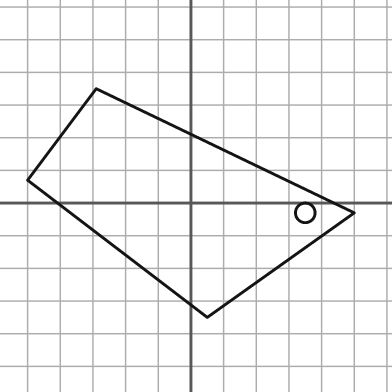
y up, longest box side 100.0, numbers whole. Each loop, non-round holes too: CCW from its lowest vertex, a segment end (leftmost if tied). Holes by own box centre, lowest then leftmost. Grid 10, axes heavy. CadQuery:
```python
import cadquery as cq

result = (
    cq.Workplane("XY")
    .moveTo(5.0, -35.0)
    .lineTo(50.0, -3.0)
    .lineTo(-29.0, 35.0)
    .lineTo(-50.0, 7.0)
    .close()
    .moveTo(35.0, -3.0)
    .circle(3.0)
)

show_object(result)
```